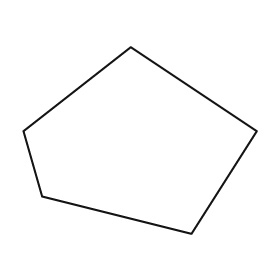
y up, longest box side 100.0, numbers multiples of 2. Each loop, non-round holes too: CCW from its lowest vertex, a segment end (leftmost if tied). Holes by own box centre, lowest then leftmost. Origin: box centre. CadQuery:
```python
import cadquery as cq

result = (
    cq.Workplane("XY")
    .moveTo(22.0, -40.0)
    .lineTo(50.0, 4.0)
    .lineTo(-4.0, 40.0)
    .lineTo(-50.0, 4.0)
    .lineTo(-42.0, -24.0)
    .close()
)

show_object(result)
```